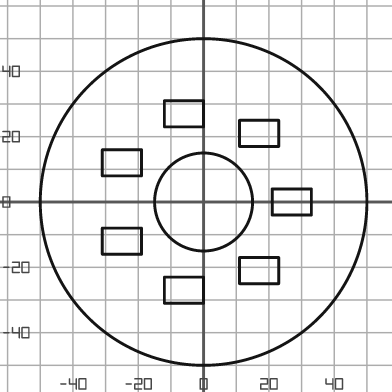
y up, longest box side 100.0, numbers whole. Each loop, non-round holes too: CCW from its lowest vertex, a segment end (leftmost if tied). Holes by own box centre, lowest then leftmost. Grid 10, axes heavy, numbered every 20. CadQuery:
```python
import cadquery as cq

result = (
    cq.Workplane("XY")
    .moveTo(0.0, 0.0)
    .circle(50.0)
    .moveTo(-12.0, -31.0)
    .lineTo(0.0, -31.0)
    .lineTo(0.0, -23.0)
    .lineTo(-12.0, -23.0)
    .close()
    .moveTo(11.0, -25.0)
    .lineTo(23.0, -25.0)
    .lineTo(23.0, -17.0)
    .lineTo(11.0, -17.0)
    .close()
    .moveTo(-31.0, -16.0)
    .lineTo(-19.0, -16.0)
    .lineTo(-19.0, -8.0)
    .lineTo(-31.0, -8.0)
    .close()
    .moveTo(0.0, 0.0)
    .circle(15.0)
    .moveTo(21.0, -4.0)
    .lineTo(33.0, -4.0)
    .lineTo(33.0, 4.0)
    .lineTo(21.0, 4.0)
    .close()
    .moveTo(-31.0, 8.0)
    .lineTo(-19.0, 8.0)
    .lineTo(-19.0, 16.0)
    .lineTo(-31.0, 16.0)
    .close()
    .moveTo(11.0, 17.0)
    .lineTo(23.0, 17.0)
    .lineTo(23.0, 25.0)
    .lineTo(11.0, 25.0)
    .close()
    .moveTo(-12.0, 23.0)
    .lineTo(0.0, 23.0)
    .lineTo(0.0, 31.0)
    .lineTo(-12.0, 31.0)
    .close()
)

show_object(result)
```